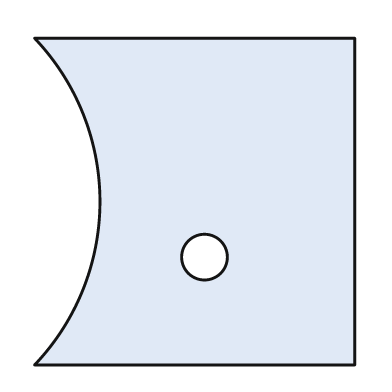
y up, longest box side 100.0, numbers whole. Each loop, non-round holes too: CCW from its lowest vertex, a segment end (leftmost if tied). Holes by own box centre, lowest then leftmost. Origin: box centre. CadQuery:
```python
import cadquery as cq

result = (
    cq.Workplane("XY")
    .moveTo(-49.0, -50.0)
    .lineTo(49.0, -50.0)
    .lineTo(49.0, 50.0)
    .lineTo(-49.0, 50.0)
    .threePointArc((-29.0, 0.0), (-49.0, -50.0))
    .close()
    .moveTo(3.0, -17.0)
    .circle(7.0)
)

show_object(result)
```